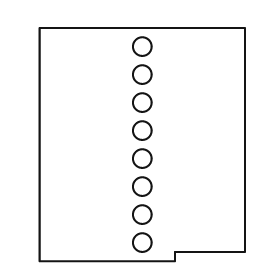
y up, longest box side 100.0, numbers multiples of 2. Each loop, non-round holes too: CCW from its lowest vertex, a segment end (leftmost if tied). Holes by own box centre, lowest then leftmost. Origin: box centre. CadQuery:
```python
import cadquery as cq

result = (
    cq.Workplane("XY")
    .moveTo(-44.0, -50.0)
    .lineTo(14.0, -50.0)
    .lineTo(14.0, -46.0)
    .lineTo(44.0, -46.0)
    .lineTo(44.0, 50.0)
    .lineTo(-44.0, 50.0)
    .close()
    .moveTo(0.0, -42.0)
    .circle(4.0)
    .moveTo(0.0, -30.0)
    .circle(4.0)
    .moveTo(0.0, -18.0)
    .circle(4.0)
    .moveTo(0.0, -6.0)
    .circle(4.0)
    .moveTo(0.0, 6.0)
    .circle(4.0)
    .moveTo(0.0, 18.0)
    .circle(4.0)
    .moveTo(0.0, 30.0)
    .circle(4.0)
    .moveTo(0.0, 42.0)
    .circle(4.0)
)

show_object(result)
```